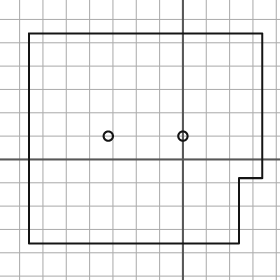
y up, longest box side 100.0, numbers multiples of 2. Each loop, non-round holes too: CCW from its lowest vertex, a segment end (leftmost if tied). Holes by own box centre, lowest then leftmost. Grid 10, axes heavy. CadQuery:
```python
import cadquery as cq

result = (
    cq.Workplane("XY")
    .moveTo(-66.0, -36.0)
    .lineTo(24.0, -36.0)
    .lineTo(24.0, -8.0)
    .lineTo(34.0, -8.0)
    .lineTo(34.0, 54.0)
    .lineTo(-66.0, 54.0)
    .close()
    .moveTo(-32.0, 10.0)
    .circle(2.0)
    .moveTo(0.0, 10.0)
    .circle(2.0)
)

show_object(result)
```